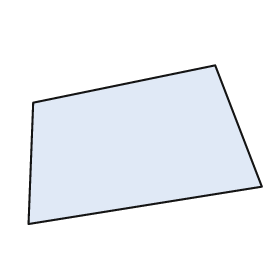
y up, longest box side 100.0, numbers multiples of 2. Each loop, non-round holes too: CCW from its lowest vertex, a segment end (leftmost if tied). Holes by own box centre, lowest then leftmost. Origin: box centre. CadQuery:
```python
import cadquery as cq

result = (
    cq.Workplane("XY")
    .moveTo(-50.0, -34.0)
    .lineTo(50.0, -18.0)
    .lineTo(30.0, 34.0)
    .lineTo(-48.0, 18.0)
    .close()
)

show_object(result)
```